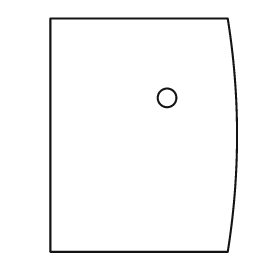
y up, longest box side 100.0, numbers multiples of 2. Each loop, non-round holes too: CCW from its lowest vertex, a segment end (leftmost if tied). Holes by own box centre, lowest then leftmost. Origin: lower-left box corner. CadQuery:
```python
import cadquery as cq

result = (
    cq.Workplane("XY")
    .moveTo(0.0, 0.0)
    .lineTo(76.0, 0.0)
    .threePointArc((80.0, 50.0), (76.0, 100.0))
    .lineTo(0.0, 100.0)
    .close()
    .moveTo(50.0, 66.0)
    .circle(4.0)
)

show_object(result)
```